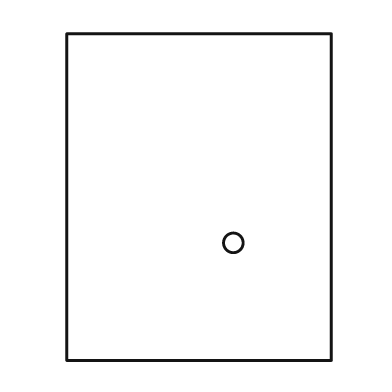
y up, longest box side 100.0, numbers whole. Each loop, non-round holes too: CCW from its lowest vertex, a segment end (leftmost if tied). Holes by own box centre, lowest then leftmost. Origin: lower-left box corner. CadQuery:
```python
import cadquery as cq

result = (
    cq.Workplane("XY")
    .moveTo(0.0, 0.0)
    .lineTo(81.0, 0.0)
    .lineTo(81.0, 100.0)
    .lineTo(0.0, 100.0)
    .close()
    .moveTo(51.0, 36.0)
    .circle(3.0)
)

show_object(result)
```